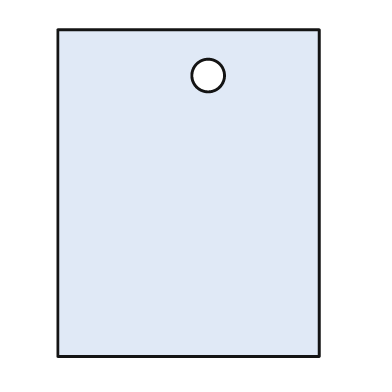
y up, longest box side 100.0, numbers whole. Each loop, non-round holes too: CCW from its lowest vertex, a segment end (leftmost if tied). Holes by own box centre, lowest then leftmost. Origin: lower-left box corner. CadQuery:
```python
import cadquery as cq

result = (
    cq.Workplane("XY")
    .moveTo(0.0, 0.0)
    .lineTo(80.0, 0.0)
    .lineTo(80.0, 100.0)
    .lineTo(0.0, 100.0)
    .close()
    .moveTo(46.0, 86.0)
    .circle(5.0)
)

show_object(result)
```